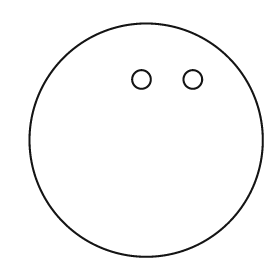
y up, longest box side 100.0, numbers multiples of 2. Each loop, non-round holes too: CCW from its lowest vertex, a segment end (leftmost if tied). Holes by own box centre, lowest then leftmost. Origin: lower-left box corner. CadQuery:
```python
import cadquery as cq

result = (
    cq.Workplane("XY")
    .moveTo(50.0, 50.0)
    .circle(50.0)
    .moveTo(48.0, 76.0)
    .circle(4.0)
    .moveTo(70.0, 76.0)
    .circle(4.0)
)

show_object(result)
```